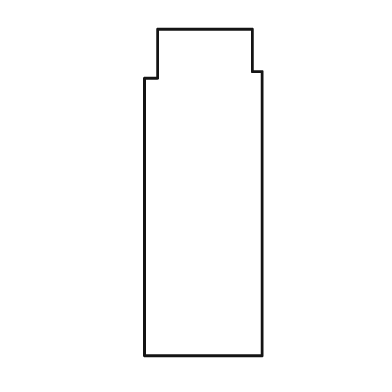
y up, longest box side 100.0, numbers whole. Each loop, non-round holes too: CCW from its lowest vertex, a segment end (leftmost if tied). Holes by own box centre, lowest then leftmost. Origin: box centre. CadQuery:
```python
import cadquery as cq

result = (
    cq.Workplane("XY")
    .moveTo(-18.0, -50.0)
    .lineTo(18.0, -50.0)
    .lineTo(18.0, 37.0)
    .lineTo(15.0, 37.0)
    .lineTo(15.0, 50.0)
    .lineTo(-14.0, 50.0)
    .lineTo(-14.0, 35.0)
    .lineTo(-18.0, 35.0)
    .close()
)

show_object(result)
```